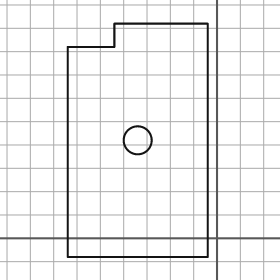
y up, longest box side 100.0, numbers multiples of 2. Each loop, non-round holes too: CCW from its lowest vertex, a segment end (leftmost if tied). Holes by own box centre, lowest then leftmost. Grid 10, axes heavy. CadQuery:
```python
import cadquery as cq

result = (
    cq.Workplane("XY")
    .moveTo(-64.0, -8.0)
    .lineTo(-4.0, -8.0)
    .lineTo(-4.0, 92.0)
    .lineTo(-44.0, 92.0)
    .lineTo(-44.0, 82.0)
    .lineTo(-64.0, 82.0)
    .close()
    .moveTo(-34.0, 42.0)
    .circle(6.0)
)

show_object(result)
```